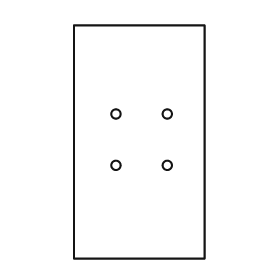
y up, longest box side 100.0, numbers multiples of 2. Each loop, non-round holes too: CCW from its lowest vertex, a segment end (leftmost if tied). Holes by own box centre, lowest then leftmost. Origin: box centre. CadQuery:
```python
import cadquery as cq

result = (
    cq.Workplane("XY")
    .moveTo(-28.0, -50.0)
    .lineTo(28.0, -50.0)
    .lineTo(28.0, 50.0)
    .lineTo(-28.0, 50.0)
    .close()
    .moveTo(-10.0, -10.0)
    .circle(2.0)
    .moveTo(12.0, -10.0)
    .circle(2.0)
    .moveTo(-10.0, 12.0)
    .circle(2.0)
    .moveTo(12.0, 12.0)
    .circle(2.0)
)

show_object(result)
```